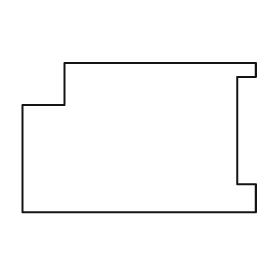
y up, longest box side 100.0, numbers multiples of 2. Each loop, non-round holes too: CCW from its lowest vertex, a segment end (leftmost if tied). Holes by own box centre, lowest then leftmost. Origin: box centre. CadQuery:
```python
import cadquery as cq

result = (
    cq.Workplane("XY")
    .moveTo(-50.0, -32.0)
    .lineTo(50.0, -32.0)
    .lineTo(50.0, -20.0)
    .lineTo(42.0, -20.0)
    .lineTo(42.0, 26.0)
    .lineTo(50.0, 26.0)
    .lineTo(50.0, 32.0)
    .lineTo(-32.0, 32.0)
    .lineTo(-32.0, 14.0)
    .lineTo(-50.0, 14.0)
    .close()
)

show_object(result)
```